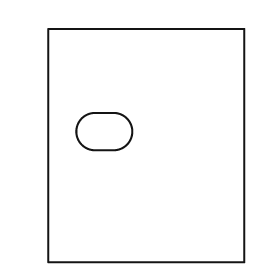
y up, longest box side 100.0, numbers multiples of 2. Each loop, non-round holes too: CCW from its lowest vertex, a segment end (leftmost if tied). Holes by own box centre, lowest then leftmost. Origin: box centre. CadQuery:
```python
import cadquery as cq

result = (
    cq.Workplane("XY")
    .moveTo(-42.0, -50.0)
    .lineTo(42.0, -50.0)
    .lineTo(42.0, 50.0)
    .lineTo(-42.0, 50.0)
    .close()
    .moveTo(-22.0, -2.0)
    .lineTo(-14.0, -2.0)
    .threePointArc((-6.0, 6.0), (-14.0, 14.0))
    .lineTo(-22.0, 14.0)
    .threePointArc((-30.0, 6.0), (-22.0, -2.0))
    .close()
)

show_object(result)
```